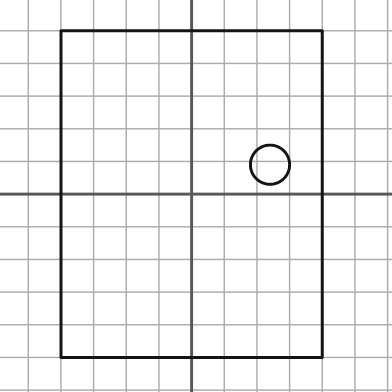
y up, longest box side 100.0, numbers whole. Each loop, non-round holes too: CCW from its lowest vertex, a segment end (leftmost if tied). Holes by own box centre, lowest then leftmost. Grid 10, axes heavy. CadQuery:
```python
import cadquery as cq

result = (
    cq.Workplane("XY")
    .moveTo(-40.0, -50.0)
    .lineTo(40.0, -50.0)
    .lineTo(40.0, 50.0)
    .lineTo(-40.0, 50.0)
    .close()
    .moveTo(24.0, 9.0)
    .circle(6.0)
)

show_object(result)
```